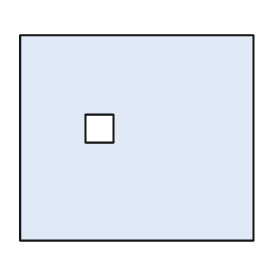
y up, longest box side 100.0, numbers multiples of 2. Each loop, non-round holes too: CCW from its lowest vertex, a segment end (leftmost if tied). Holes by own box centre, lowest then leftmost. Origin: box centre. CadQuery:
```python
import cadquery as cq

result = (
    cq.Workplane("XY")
    .moveTo(-50.0, -44.0)
    .lineTo(50.0, -44.0)
    .lineTo(50.0, 44.0)
    .lineTo(-50.0, 44.0)
    .close()
    .moveTo(-22.0, -2.0)
    .lineTo(-10.0, -2.0)
    .lineTo(-10.0, 10.0)
    .lineTo(-22.0, 10.0)
    .close()
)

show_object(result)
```